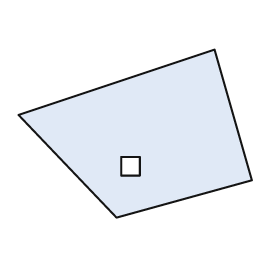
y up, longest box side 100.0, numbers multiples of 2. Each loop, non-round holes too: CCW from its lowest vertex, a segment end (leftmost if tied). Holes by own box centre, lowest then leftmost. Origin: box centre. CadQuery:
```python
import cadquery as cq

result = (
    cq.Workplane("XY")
    .moveTo(-8.0, -36.0)
    .lineTo(50.0, -20.0)
    .lineTo(34.0, 36.0)
    .lineTo(-50.0, 8.0)
    .close()
    .moveTo(-6.0, -18.0)
    .lineTo(2.0, -18.0)
    .lineTo(2.0, -10.0)
    .lineTo(-6.0, -10.0)
    .close()
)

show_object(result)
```